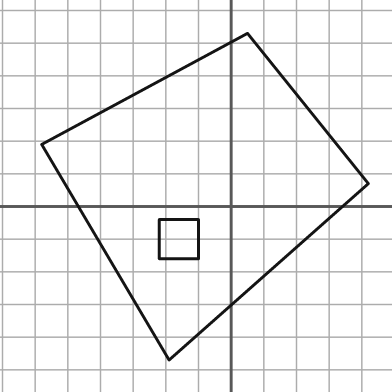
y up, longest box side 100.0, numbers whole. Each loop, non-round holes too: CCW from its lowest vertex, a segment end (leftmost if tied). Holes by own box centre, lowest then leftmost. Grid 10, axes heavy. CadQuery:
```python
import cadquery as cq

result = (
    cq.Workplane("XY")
    .moveTo(-19.0, -47.0)
    .lineTo(42.0, 7.0)
    .lineTo(5.0, 53.0)
    .lineTo(-58.0, 19.0)
    .close()
    .moveTo(-22.0, -16.0)
    .lineTo(-10.0, -16.0)
    .lineTo(-10.0, -4.0)
    .lineTo(-22.0, -4.0)
    .close()
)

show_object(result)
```